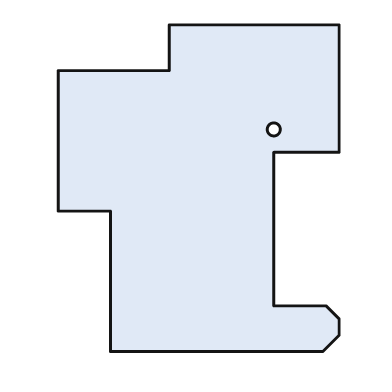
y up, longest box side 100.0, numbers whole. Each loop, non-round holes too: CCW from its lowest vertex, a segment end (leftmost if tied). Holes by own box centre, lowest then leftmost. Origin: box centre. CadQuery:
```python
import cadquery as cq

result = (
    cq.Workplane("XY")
    .moveTo(-27.0, -50.0)
    .lineTo(38.0, -50.0)
    .lineTo(43.0, -45.0)
    .lineTo(43.0, -40.0)
    .lineTo(39.0, -36.0)
    .lineTo(23.0, -36.0)
    .lineTo(23.0, 11.0)
    .lineTo(43.0, 11.0)
    .lineTo(43.0, 50.0)
    .lineTo(-9.0, 50.0)
    .lineTo(-9.0, 36.0)
    .lineTo(-43.0, 36.0)
    .lineTo(-43.0, -7.0)
    .lineTo(-27.0, -7.0)
    .close()
    .moveTo(23.0, 18.0)
    .circle(2.0)
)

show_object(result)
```